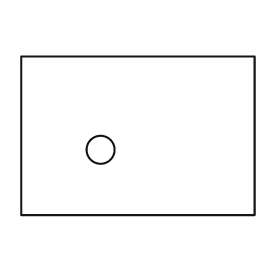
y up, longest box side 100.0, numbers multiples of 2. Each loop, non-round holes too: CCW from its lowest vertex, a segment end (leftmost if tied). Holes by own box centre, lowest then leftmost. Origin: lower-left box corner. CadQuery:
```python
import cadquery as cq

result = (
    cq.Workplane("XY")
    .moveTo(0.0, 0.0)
    .lineTo(100.0, 0.0)
    .lineTo(100.0, 68.0)
    .lineTo(0.0, 68.0)
    .close()
    .moveTo(34.0, 28.0)
    .circle(6.0)
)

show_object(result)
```